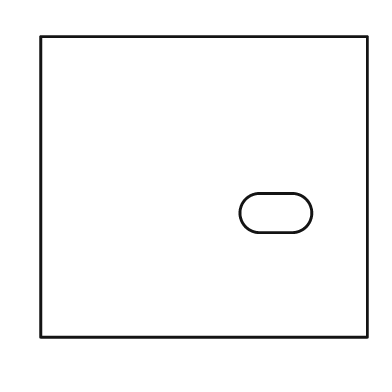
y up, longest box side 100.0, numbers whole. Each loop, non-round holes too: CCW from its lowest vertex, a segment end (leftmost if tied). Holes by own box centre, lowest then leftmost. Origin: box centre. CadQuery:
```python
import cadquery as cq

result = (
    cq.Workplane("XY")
    .moveTo(-50.0, -46.0)
    .lineTo(50.0, -46.0)
    .lineTo(50.0, 46.0)
    .lineTo(-50.0, 46.0)
    .close()
    .moveTo(17.0, -14.0)
    .lineTo(27.0, -14.0)
    .threePointArc((33.0, -8.0), (27.0, -2.0))
    .lineTo(17.0, -2.0)
    .threePointArc((11.0, -8.0), (17.0, -14.0))
    .close()
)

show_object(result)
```